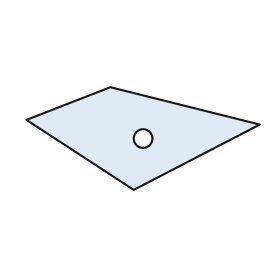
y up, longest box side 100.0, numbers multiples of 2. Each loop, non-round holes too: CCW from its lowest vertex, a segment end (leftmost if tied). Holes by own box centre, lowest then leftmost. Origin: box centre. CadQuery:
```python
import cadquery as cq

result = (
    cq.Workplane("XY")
    .moveTo(-4.0, -22.0)
    .lineTo(50.0, 6.0)
    .lineTo(-14.0, 22.0)
    .lineTo(-50.0, 8.0)
    .close()
    .moveTo(0.0, 0.0)
    .circle(4.0)
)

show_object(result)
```